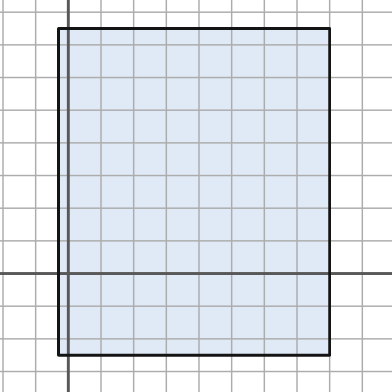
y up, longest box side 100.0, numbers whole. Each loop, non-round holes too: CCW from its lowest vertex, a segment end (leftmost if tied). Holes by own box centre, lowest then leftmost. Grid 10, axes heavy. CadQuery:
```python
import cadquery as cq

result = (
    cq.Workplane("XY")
    .moveTo(-3.0, -25.0)
    .lineTo(80.0, -25.0)
    .lineTo(80.0, 75.0)
    .lineTo(-3.0, 75.0)
    .close()
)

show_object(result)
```